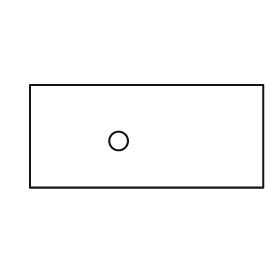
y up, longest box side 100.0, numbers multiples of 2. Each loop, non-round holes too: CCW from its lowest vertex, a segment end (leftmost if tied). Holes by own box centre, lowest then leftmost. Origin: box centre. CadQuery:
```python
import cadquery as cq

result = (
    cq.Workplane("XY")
    .moveTo(-50.0, -22.0)
    .lineTo(50.0, -22.0)
    .lineTo(50.0, 22.0)
    .lineTo(-50.0, 22.0)
    .close()
    .moveTo(-12.0, -2.0)
    .circle(4.0)
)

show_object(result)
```